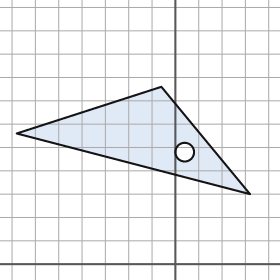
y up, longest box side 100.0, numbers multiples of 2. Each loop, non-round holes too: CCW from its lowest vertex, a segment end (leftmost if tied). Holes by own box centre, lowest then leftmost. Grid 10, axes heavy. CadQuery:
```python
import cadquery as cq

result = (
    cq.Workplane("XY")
    .moveTo(32.0, 30.0)
    .lineTo(-6.0, 76.0)
    .lineTo(-68.0, 56.0)
    .close()
    .moveTo(4.0, 48.0)
    .circle(4.0)
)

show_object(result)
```